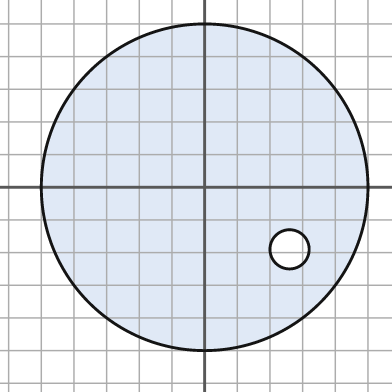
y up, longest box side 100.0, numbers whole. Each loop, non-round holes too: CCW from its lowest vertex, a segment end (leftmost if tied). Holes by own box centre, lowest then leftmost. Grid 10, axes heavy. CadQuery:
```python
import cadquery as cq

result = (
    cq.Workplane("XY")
    .moveTo(0.0, 0.0)
    .circle(50.0)
    .moveTo(26.0, -19.0)
    .circle(6.0)
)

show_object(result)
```